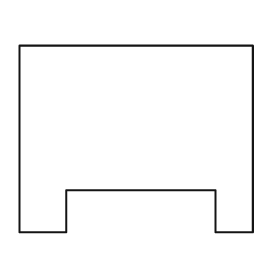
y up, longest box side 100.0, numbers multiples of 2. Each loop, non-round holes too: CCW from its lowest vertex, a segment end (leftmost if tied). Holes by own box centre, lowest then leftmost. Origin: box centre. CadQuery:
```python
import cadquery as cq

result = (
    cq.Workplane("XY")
    .moveTo(-50.0, -40.0)
    .lineTo(-30.0, -40.0)
    .lineTo(-30.0, -22.0)
    .lineTo(34.0, -22.0)
    .lineTo(34.0, -40.0)
    .lineTo(50.0, -40.0)
    .lineTo(50.0, 40.0)
    .lineTo(-50.0, 40.0)
    .close()
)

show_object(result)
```